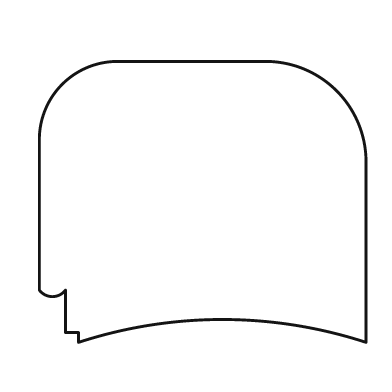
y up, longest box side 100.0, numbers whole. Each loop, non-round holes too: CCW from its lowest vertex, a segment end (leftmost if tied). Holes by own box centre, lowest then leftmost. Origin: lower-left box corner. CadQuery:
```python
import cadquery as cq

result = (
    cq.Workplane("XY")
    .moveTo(12.0, 0.0)
    .threePointArc((56.0, 7.0), (100.0, 0.0))
    .lineTo(100.0, 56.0)
    .threePointArc((91.0, 77.0), (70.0, 86.0))
    .lineTo(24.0, 86.0)
    .threePointArc((7.0, 79.0), (0.0, 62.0))
    .lineTo(0.0, 16.0)
    .threePointArc((4.0, 14.0), (8.0, 16.0))
    .lineTo(8.0, 3.0)
    .lineTo(12.0, 3.0)
    .close()
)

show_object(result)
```